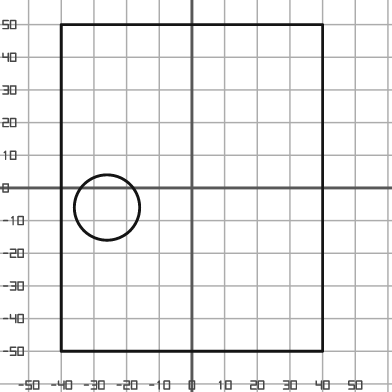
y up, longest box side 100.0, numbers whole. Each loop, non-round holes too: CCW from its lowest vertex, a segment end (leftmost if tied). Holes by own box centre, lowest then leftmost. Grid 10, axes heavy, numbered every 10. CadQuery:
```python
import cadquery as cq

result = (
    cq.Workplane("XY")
    .moveTo(-40.0, -50.0)
    .lineTo(40.0, -50.0)
    .lineTo(40.0, 50.0)
    .lineTo(-40.0, 50.0)
    .close()
    .moveTo(-26.0, -6.0)
    .circle(10.0)
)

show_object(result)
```